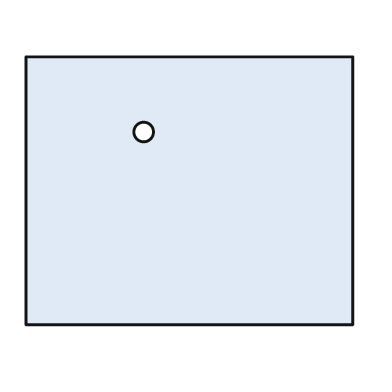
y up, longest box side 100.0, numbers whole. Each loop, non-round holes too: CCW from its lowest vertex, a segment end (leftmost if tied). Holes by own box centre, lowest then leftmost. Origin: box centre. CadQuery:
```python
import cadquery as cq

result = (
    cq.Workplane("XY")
    .moveTo(-50.0, -41.0)
    .lineTo(50.0, -41.0)
    .lineTo(50.0, 41.0)
    .lineTo(-50.0, 41.0)
    .close()
    .moveTo(-14.0, 18.0)
    .circle(3.0)
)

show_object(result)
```